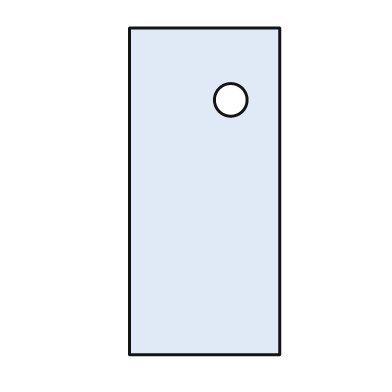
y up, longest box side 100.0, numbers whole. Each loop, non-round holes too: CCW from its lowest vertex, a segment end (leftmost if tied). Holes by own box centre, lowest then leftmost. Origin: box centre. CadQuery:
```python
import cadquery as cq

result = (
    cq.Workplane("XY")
    .moveTo(-23.0, -50.0)
    .lineTo(23.0, -50.0)
    .lineTo(23.0, 50.0)
    .lineTo(-23.0, 50.0)
    .close()
    .moveTo(8.0, 28.0)
    .circle(5.0)
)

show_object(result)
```